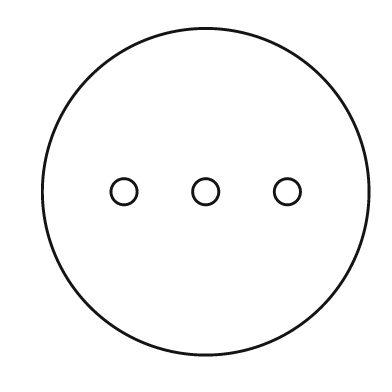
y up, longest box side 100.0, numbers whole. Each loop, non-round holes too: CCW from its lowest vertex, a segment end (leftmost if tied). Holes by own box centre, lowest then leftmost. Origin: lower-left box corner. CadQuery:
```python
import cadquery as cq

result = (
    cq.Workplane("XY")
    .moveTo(50.0, 50.0)
    .circle(50.0)
    .moveTo(25.0, 50.0)
    .circle(4.0)
    .moveTo(50.0, 50.0)
    .circle(4.0)
    .moveTo(75.0, 50.0)
    .circle(4.0)
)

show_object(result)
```